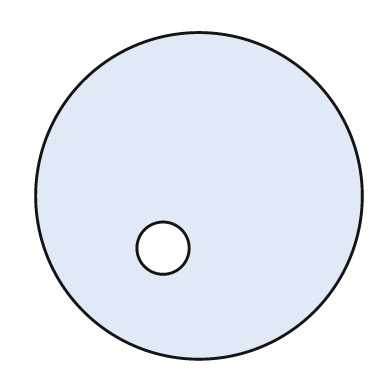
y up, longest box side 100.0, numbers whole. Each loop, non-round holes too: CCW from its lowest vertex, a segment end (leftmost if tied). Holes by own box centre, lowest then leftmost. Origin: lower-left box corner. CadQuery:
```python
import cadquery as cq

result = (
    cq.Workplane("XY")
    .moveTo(50.0, 50.0)
    .circle(50.0)
    .moveTo(39.0, 34.0)
    .circle(8.0)
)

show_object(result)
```